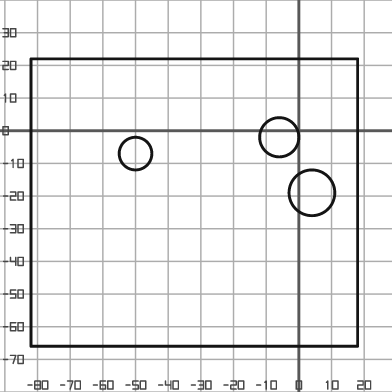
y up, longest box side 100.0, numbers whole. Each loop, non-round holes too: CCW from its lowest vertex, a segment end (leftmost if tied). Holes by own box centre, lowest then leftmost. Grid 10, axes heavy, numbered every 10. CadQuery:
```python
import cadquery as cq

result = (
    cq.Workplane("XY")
    .moveTo(-82.0, -66.0)
    .lineTo(18.0, -66.0)
    .lineTo(18.0, 22.0)
    .lineTo(-82.0, 22.0)
    .close()
    .moveTo(4.0, -19.0)
    .circle(7.0)
    .moveTo(-50.0, -7.0)
    .circle(5.0)
    .moveTo(-6.0, -2.0)
    .circle(6.0)
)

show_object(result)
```